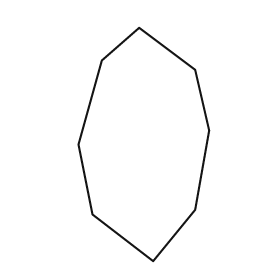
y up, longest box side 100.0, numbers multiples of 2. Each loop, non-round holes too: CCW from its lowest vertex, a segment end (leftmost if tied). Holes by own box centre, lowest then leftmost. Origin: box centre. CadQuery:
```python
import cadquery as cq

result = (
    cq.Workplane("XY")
    .moveTo(4.0, -50.0)
    .lineTo(22.0, -28.0)
    .lineTo(28.0, 6.0)
    .lineTo(22.0, 32.0)
    .lineTo(-2.0, 50.0)
    .lineTo(-18.0, 36.0)
    .lineTo(-28.0, 0.0)
    .lineTo(-22.0, -30.0)
    .close()
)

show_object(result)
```